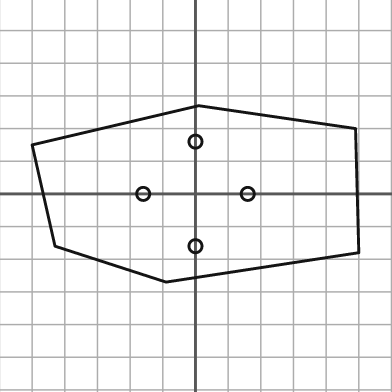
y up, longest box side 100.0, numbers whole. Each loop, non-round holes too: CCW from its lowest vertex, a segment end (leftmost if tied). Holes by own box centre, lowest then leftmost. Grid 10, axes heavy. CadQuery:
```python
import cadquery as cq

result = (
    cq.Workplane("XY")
    .moveTo(-9.0, -27.0)
    .lineTo(50.0, -18.0)
    .lineTo(49.0, 20.0)
    .lineTo(1.0, 27.0)
    .lineTo(-50.0, 15.0)
    .lineTo(-43.0, -16.0)
    .close()
    .moveTo(0.0, -16.0)
    .circle(2.0)
    .moveTo(-16.0, 0.0)
    .circle(2.0)
    .moveTo(16.0, 0.0)
    .circle(2.0)
    .moveTo(0.0, 16.0)
    .circle(2.0)
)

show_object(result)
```